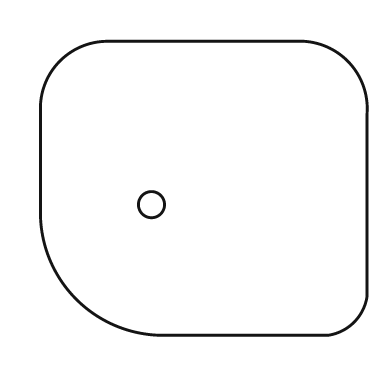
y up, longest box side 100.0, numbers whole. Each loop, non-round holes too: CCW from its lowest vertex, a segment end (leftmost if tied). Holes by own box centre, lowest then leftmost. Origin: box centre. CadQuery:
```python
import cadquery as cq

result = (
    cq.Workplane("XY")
    .moveTo(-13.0, -45.0)
    .lineTo(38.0, -45.0)
    .threePointArc((46.0, -41.0), (50.0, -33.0))
    .lineTo(50.0, 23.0)
    .threePointArc((44.0, 39.0), (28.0, 45.0))
    .lineTo(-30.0, 45.0)
    .threePointArc((-44.0, 39.0), (-50.0, 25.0))
    .lineTo(-50.0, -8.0)
    .threePointArc((-39.0, -34.0), (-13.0, -45.0))
    .close()
    .moveTo(-16.0, -5.0)
    .circle(4.0)
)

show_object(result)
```